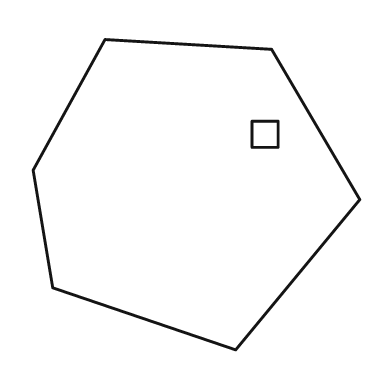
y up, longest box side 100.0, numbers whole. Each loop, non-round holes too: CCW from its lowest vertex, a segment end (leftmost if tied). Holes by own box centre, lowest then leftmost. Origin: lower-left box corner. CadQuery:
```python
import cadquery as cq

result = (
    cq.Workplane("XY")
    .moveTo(62.0, 0.0)
    .lineTo(100.0, 46.0)
    .lineTo(73.0, 92.0)
    .lineTo(22.0, 95.0)
    .lineTo(0.0, 55.0)
    .lineTo(6.0, 19.0)
    .close()
    .moveTo(67.0, 62.0)
    .lineTo(75.0, 62.0)
    .lineTo(75.0, 70.0)
    .lineTo(67.0, 70.0)
    .close()
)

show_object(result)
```